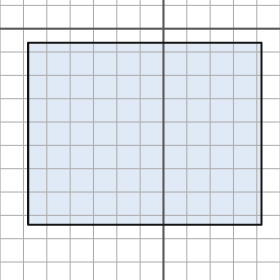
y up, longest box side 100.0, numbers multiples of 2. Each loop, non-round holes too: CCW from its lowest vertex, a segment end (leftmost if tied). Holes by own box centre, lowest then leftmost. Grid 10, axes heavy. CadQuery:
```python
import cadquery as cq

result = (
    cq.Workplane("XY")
    .moveTo(-58.0, -84.0)
    .lineTo(42.0, -84.0)
    .lineTo(42.0, -6.0)
    .lineTo(-58.0, -6.0)
    .close()
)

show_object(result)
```